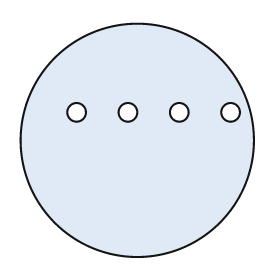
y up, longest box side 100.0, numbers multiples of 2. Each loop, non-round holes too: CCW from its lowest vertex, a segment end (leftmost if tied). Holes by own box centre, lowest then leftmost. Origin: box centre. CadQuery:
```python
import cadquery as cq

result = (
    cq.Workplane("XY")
    .moveTo(0.0, 0.0)
    .circle(50.0)
    .moveTo(-26.0, 12.0)
    .circle(4.0)
    .moveTo(-4.0, 12.0)
    .circle(4.0)
    .moveTo(18.0, 12.0)
    .circle(4.0)
    .moveTo(40.0, 12.0)
    .circle(4.0)
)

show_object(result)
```